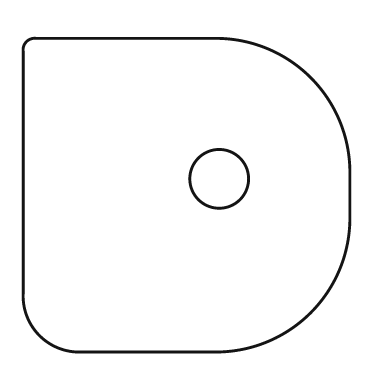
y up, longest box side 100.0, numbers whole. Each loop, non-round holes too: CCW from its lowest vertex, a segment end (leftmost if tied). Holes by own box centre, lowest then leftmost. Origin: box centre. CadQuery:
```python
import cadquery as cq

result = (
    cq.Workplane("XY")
    .moveTo(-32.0, -48.0)
    .lineTo(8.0, -48.0)
    .threePointArc((38.0, -36.0), (50.0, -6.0))
    .lineTo(50.0, 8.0)
    .threePointArc((38.0, 36.0), (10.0, 48.0))
    .lineTo(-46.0, 48.0)
    .threePointArc((-49.0, 47.0), (-50.0, 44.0))
    .lineTo(-50.0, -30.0)
    .threePointArc((-45.0, -43.0), (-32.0, -48.0))
    .close()
    .moveTo(10.0, 5.0)
    .circle(9.0)
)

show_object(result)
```